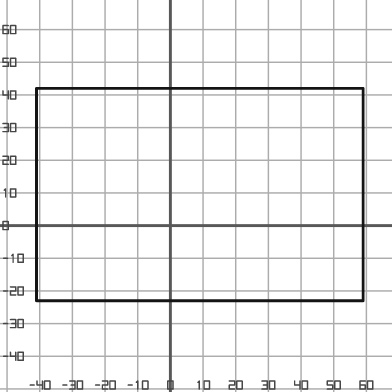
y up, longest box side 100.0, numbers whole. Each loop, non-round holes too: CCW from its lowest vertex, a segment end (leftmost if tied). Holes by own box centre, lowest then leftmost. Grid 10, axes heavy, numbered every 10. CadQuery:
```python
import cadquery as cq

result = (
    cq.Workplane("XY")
    .moveTo(-41.0, -23.0)
    .lineTo(59.0, -23.0)
    .lineTo(59.0, 42.0)
    .lineTo(-41.0, 42.0)
    .close()
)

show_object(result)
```